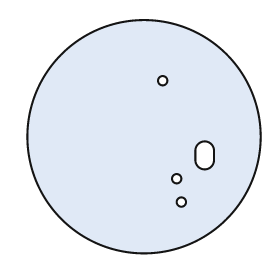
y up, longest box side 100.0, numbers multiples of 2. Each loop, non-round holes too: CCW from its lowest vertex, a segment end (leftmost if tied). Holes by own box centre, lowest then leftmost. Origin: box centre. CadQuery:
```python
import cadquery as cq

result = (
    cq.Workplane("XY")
    .moveTo(0.0, 0.0)
    .circle(50.0)
    .moveTo(16.0, -28.0)
    .circle(2.0)
    .moveTo(14.0, -18.0)
    .circle(2.0)
    .moveTo(22.0, -10.0)
    .threePointArc((26.0, -14.0), (30.0, -10.0))
    .lineTo(30.0, -6.0)
    .threePointArc((26.0, -2.0), (22.0, -6.0))
    .close()
    .moveTo(8.0, 24.0)
    .circle(2.0)
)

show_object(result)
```